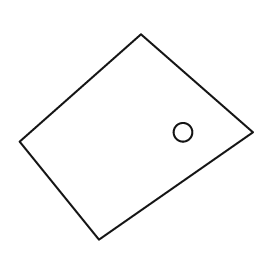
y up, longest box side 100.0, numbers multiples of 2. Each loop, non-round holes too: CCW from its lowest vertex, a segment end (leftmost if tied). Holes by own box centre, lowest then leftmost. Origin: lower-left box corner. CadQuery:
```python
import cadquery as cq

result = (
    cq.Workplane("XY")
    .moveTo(34.0, 0.0)
    .lineTo(100.0, 46.0)
    .lineTo(52.0, 88.0)
    .lineTo(0.0, 42.0)
    .close()
    .moveTo(70.0, 46.0)
    .circle(4.0)
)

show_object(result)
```